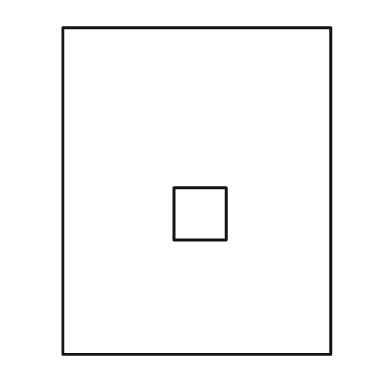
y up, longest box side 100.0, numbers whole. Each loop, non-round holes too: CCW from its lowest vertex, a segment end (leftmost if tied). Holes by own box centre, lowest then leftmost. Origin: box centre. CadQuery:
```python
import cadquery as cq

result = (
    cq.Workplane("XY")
    .moveTo(-41.0, -50.0)
    .lineTo(41.0, -50.0)
    .lineTo(41.0, 50.0)
    .lineTo(-41.0, 50.0)
    .close()
    .moveTo(-7.0, -15.0)
    .lineTo(9.0, -15.0)
    .lineTo(9.0, 1.0)
    .lineTo(-7.0, 1.0)
    .close()
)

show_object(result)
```